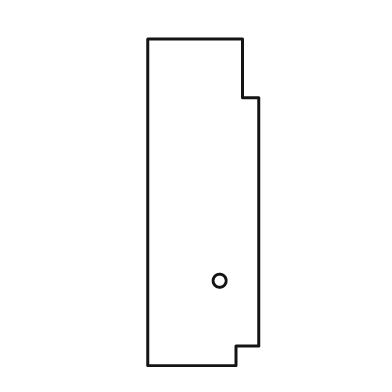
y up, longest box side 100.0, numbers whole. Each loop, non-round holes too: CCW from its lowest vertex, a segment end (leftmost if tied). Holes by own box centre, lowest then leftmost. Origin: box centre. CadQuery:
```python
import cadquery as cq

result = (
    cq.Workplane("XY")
    .moveTo(-17.0, -50.0)
    .lineTo(10.0, -50.0)
    .lineTo(10.0, -44.0)
    .lineTo(17.0, -44.0)
    .lineTo(17.0, 32.0)
    .lineTo(12.0, 32.0)
    .lineTo(12.0, 50.0)
    .lineTo(-17.0, 50.0)
    .close()
    .moveTo(5.0, -24.0)
    .circle(2.0)
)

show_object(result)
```